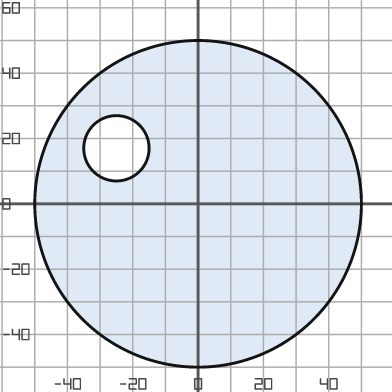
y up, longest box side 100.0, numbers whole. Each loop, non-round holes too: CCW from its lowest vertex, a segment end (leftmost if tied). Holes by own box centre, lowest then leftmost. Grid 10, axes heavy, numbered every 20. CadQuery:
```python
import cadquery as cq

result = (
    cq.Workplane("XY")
    .moveTo(0.0, 0.0)
    .circle(50.0)
    .moveTo(-25.0, 17.0)
    .circle(10.0)
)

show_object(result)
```